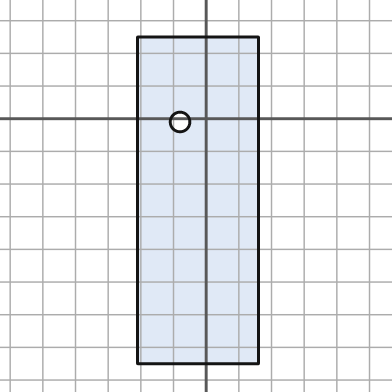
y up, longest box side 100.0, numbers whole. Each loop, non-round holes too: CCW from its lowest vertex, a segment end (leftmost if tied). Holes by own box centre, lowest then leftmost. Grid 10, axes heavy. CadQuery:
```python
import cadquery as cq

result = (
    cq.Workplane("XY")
    .moveTo(-21.0, -75.0)
    .lineTo(16.0, -75.0)
    .lineTo(16.0, 25.0)
    .lineTo(-21.0, 25.0)
    .close()
    .moveTo(-8.0, -1.0)
    .circle(3.0)
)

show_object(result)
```